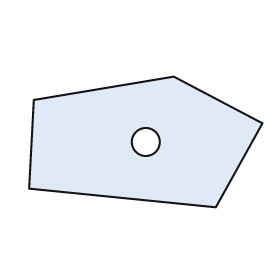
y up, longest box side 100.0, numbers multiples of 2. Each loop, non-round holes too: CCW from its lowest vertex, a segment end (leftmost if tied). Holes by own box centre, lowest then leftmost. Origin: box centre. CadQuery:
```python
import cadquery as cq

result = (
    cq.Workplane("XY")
    .moveTo(30.0, -28.0)
    .lineTo(50.0, 8.0)
    .lineTo(12.0, 28.0)
    .lineTo(-48.0, 18.0)
    .lineTo(-50.0, -20.0)
    .close()
    .moveTo(0.0, 0.0)
    .circle(6.0)
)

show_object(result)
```